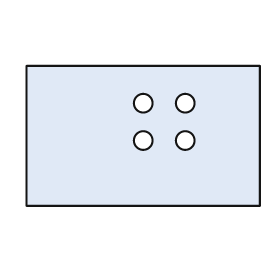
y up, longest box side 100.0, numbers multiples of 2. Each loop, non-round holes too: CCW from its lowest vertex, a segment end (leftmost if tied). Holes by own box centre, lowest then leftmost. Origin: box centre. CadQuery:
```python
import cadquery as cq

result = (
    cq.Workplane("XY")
    .moveTo(-50.0, -30.0)
    .lineTo(50.0, -30.0)
    .lineTo(50.0, 30.0)
    .lineTo(-50.0, 30.0)
    .close()
    .moveTo(0.0, -2.0)
    .circle(4.0)
    .moveTo(18.0, -2.0)
    .circle(4.0)
    .moveTo(0.0, 14.0)
    .circle(4.0)
    .moveTo(18.0, 14.0)
    .circle(4.0)
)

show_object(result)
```